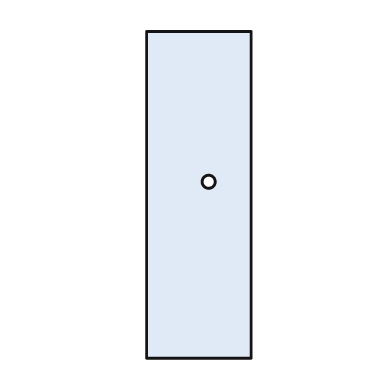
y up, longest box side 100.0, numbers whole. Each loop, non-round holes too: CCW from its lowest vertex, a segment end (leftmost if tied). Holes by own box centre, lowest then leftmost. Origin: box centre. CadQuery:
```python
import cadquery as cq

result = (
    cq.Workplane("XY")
    .moveTo(-16.0, -50.0)
    .lineTo(16.0, -50.0)
    .lineTo(16.0, 50.0)
    .lineTo(-16.0, 50.0)
    .close()
    .moveTo(3.0, 4.0)
    .circle(2.0)
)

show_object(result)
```